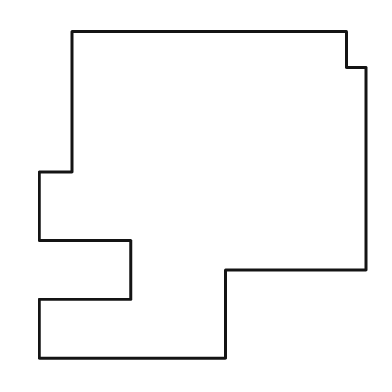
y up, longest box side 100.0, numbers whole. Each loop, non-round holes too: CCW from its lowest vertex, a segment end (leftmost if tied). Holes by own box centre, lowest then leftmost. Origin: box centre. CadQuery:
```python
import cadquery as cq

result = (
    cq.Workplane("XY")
    .moveTo(-50.0, -50.0)
    .lineTo(7.0, -50.0)
    .lineTo(7.0, -23.0)
    .lineTo(50.0, -23.0)
    .lineTo(50.0, 39.0)
    .lineTo(44.0, 39.0)
    .lineTo(44.0, 50.0)
    .lineTo(-40.0, 50.0)
    .lineTo(-40.0, 7.0)
    .lineTo(-50.0, 7.0)
    .lineTo(-50.0, -14.0)
    .lineTo(-22.0, -14.0)
    .lineTo(-22.0, -32.0)
    .lineTo(-50.0, -32.0)
    .close()
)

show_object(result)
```